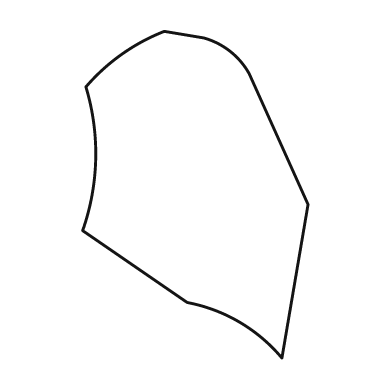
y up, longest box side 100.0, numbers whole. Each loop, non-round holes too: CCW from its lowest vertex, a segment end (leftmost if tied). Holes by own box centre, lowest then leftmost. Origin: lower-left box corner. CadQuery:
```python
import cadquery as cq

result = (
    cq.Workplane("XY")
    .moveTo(61.0, 0.0)
    .lineTo(69.0, 47.0)
    .lineTo(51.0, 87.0)
    .threePointArc((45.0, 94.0), (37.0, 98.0))
    .lineTo(25.0, 100.0)
    .threePointArc((12.0, 93.0), (1.0, 83.0))
    .threePointArc((4.0, 61.0), (0.0, 39.0))
    .lineTo(32.0, 17.0)
    .threePointArc((48.0, 11.0), (61.0, 0.0))
    .close()
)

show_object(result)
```